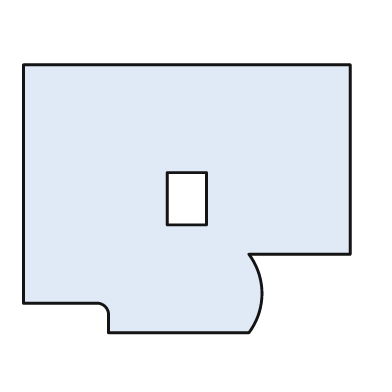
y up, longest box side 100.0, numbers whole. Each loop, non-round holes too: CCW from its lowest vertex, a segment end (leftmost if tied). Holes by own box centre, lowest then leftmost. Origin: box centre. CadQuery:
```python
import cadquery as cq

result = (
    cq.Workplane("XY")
    .moveTo(-24.0, -41.0)
    .lineTo(19.0, -41.0)
    .threePointArc((23.0, -29.0), (19.0, -17.0))
    .lineTo(50.0, -17.0)
    .lineTo(50.0, 41.0)
    .lineTo(-50.0, 41.0)
    .lineTo(-50.0, -32.0)
    .lineTo(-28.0, -32.0)
    .threePointArc((-25.0, -33.0), (-24.0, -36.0))
    .close()
    .moveTo(-6.0, -8.0)
    .lineTo(6.0, -8.0)
    .lineTo(6.0, 8.0)
    .lineTo(-6.0, 8.0)
    .close()
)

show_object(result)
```